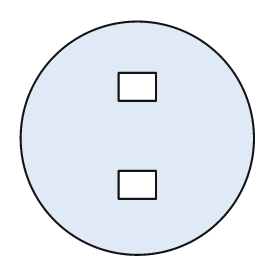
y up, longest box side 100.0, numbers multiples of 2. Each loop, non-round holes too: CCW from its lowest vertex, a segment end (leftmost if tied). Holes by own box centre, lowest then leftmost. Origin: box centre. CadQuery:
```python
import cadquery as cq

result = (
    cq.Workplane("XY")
    .moveTo(0.0, 0.0)
    .circle(50.0)
    .moveTo(-8.0, -26.0)
    .lineTo(8.0, -26.0)
    .lineTo(8.0, -14.0)
    .lineTo(-8.0, -14.0)
    .close()
    .moveTo(-8.0, 16.0)
    .lineTo(8.0, 16.0)
    .lineTo(8.0, 28.0)
    .lineTo(-8.0, 28.0)
    .close()
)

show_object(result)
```